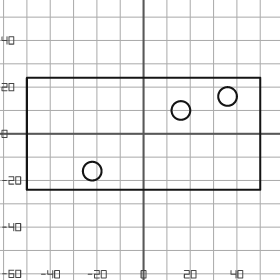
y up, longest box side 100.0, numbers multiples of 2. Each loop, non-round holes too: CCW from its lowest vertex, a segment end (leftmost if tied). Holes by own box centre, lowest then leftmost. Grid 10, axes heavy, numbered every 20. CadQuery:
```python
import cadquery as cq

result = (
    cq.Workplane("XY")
    .moveTo(-50.0, -24.0)
    .lineTo(50.0, -24.0)
    .lineTo(50.0, 24.0)
    .lineTo(-50.0, 24.0)
    .close()
    .moveTo(-22.0, -16.0)
    .circle(4.0)
    .moveTo(16.0, 10.0)
    .circle(4.0)
    .moveTo(36.0, 16.0)
    .circle(4.0)
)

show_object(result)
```